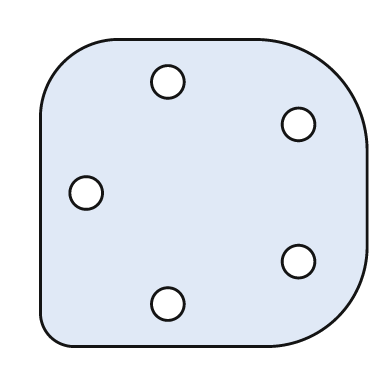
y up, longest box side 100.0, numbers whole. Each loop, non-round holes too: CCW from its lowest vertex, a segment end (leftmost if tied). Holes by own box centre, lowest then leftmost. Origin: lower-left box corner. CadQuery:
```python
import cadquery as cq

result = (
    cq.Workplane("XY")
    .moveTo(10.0, 0.0)
    .lineTo(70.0, 0.0)
    .threePointArc((91.0, 9.0), (100.0, 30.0))
    .lineTo(100.0, 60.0)
    .threePointArc((90.0, 84.0), (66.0, 94.0))
    .lineTo(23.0, 94.0)
    .threePointArc((7.0, 87.0), (0.0, 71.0))
    .lineTo(0.0, 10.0)
    .threePointArc((3.0, 3.0), (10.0, 0.0))
    .close()
    .moveTo(39.0, 13.0)
    .circle(5.0)
    .moveTo(79.0, 26.0)
    .circle(5.0)
    .moveTo(14.0, 47.0)
    .circle(5.0)
    .moveTo(79.0, 68.0)
    .circle(5.0)
    .moveTo(39.0, 81.0)
    .circle(5.0)
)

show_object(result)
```